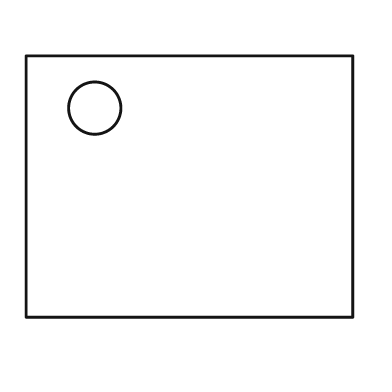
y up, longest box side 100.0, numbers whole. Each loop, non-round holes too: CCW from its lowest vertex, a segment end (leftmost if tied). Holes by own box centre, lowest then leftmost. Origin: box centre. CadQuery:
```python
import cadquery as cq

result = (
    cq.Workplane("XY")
    .moveTo(-50.0, -40.0)
    .lineTo(50.0, -40.0)
    .lineTo(50.0, 40.0)
    .lineTo(-50.0, 40.0)
    .close()
    .moveTo(-29.0, 24.0)
    .circle(8.0)
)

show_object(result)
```